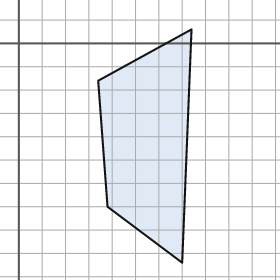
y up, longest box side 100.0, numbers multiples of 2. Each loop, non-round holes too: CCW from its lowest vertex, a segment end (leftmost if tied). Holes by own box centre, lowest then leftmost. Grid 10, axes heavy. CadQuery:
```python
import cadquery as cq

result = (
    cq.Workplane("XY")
    .moveTo(70.0, -94.0)
    .lineTo(74.0, 6.0)
    .lineTo(34.0, -16.0)
    .lineTo(38.0, -70.0)
    .close()
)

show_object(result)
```